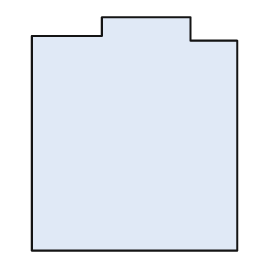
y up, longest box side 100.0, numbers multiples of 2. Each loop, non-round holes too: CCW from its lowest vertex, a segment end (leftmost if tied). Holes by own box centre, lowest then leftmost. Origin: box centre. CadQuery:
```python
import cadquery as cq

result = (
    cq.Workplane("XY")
    .moveTo(-44.0, -50.0)
    .lineTo(44.0, -50.0)
    .lineTo(44.0, 40.0)
    .lineTo(24.0, 40.0)
    .lineTo(24.0, 50.0)
    .lineTo(-14.0, 50.0)
    .lineTo(-14.0, 42.0)
    .lineTo(-44.0, 42.0)
    .close()
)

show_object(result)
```